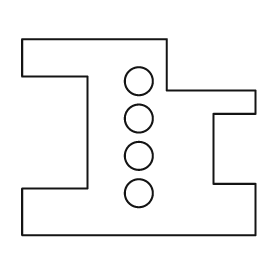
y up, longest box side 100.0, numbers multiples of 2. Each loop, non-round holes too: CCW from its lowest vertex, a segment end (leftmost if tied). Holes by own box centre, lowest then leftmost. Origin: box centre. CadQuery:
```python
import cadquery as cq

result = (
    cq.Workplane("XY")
    .moveTo(-50.0, -42.0)
    .lineTo(50.0, -42.0)
    .lineTo(50.0, -20.0)
    .lineTo(32.0, -20.0)
    .lineTo(32.0, 10.0)
    .lineTo(50.0, 10.0)
    .lineTo(50.0, 20.0)
    .lineTo(12.0, 20.0)
    .lineTo(12.0, 42.0)
    .lineTo(-50.0, 42.0)
    .lineTo(-50.0, 26.0)
    .lineTo(-22.0, 26.0)
    .lineTo(-22.0, -22.0)
    .lineTo(-50.0, -22.0)
    .close()
    .moveTo(0.0, -24.0)
    .circle(6.0)
    .moveTo(0.0, -8.0)
    .circle(6.0)
    .moveTo(0.0, 8.0)
    .circle(6.0)
    .moveTo(0.0, 24.0)
    .circle(6.0)
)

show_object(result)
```